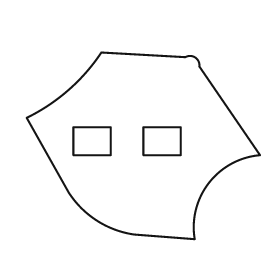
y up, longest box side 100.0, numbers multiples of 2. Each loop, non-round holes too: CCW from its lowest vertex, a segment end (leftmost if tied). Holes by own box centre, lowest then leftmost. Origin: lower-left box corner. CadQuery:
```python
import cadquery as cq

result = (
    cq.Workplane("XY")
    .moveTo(72.0, 0.0)
    .threePointArc((78.0, 24.0), (100.0, 36.0))
    .lineTo(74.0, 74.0)
    .threePointArc((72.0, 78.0), (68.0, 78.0))
    .lineTo(32.0, 80.0)
    .threePointArc((18.0, 64.0), (0.0, 52.0))
    .lineTo(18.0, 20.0)
    .threePointArc((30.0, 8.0), (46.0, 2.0))
    .close()
    .moveTo(20.0, 36.0)
    .lineTo(36.0, 36.0)
    .lineTo(36.0, 48.0)
    .lineTo(20.0, 48.0)
    .close()
    .moveTo(50.0, 36.0)
    .lineTo(66.0, 36.0)
    .lineTo(66.0, 48.0)
    .lineTo(50.0, 48.0)
    .close()
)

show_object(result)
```